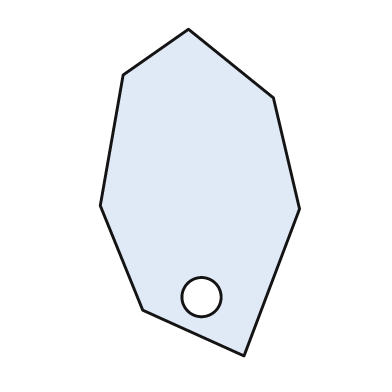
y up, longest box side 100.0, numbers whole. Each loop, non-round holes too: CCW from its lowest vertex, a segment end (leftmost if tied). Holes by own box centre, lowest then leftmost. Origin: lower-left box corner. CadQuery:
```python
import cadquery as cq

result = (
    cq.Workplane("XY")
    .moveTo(44.0, 0.0)
    .lineTo(61.0, 45.0)
    .lineTo(53.0, 79.0)
    .lineTo(27.0, 100.0)
    .lineTo(7.0, 86.0)
    .lineTo(0.0, 46.0)
    .lineTo(13.0, 14.0)
    .close()
    .moveTo(31.0, 18.0)
    .circle(6.0)
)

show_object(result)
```